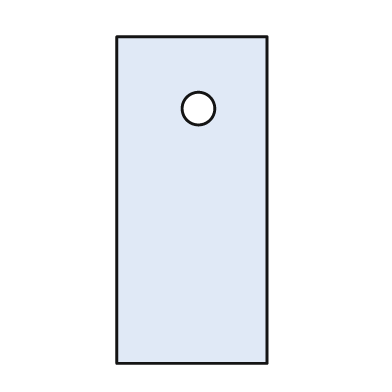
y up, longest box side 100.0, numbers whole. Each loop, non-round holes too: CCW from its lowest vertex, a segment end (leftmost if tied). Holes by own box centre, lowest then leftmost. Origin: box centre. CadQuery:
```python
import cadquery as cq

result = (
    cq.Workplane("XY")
    .moveTo(-23.0, -50.0)
    .lineTo(23.0, -50.0)
    .lineTo(23.0, 50.0)
    .lineTo(-23.0, 50.0)
    .close()
    .moveTo(2.0, 28.0)
    .circle(5.0)
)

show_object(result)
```